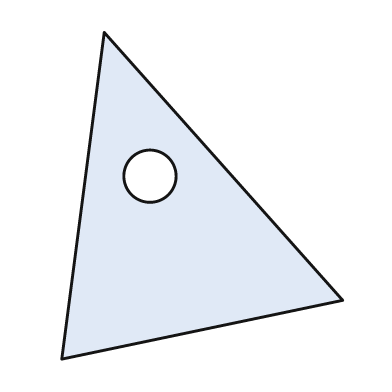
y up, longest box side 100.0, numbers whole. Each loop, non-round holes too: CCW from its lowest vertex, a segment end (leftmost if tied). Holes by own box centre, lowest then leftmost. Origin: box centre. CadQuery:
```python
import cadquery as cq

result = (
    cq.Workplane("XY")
    .moveTo(-43.0, -50.0)
    .lineTo(43.0, -32.0)
    .lineTo(-30.0, 50.0)
    .close()
    .moveTo(-16.0, 6.0)
    .circle(8.0)
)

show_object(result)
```